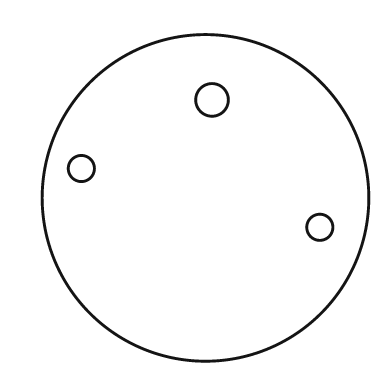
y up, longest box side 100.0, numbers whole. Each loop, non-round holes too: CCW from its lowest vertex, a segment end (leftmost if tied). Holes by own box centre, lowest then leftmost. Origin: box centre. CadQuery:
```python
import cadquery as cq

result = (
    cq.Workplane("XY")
    .moveTo(0.0, 0.0)
    .circle(50.0)
    .moveTo(35.0, -9.0)
    .circle(4.0)
    .moveTo(-38.0, 9.0)
    .circle(4.0)
    .moveTo(2.0, 30.0)
    .circle(5.0)
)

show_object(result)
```